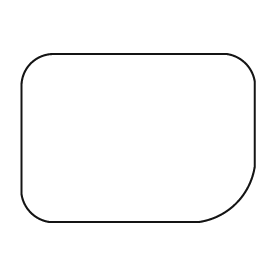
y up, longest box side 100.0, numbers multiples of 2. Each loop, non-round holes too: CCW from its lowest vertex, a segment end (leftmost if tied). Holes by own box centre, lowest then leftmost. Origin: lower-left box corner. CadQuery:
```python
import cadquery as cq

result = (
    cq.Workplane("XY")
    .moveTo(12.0, 0.0)
    .lineTo(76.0, 0.0)
    .threePointArc((92.0, 8.0), (100.0, 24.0))
    .lineTo(100.0, 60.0)
    .threePointArc((96.0, 68.0), (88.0, 72.0))
    .lineTo(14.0, 72.0)
    .threePointArc((4.0, 68.0), (0.0, 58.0))
    .lineTo(0.0, 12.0)
    .threePointArc((4.0, 4.0), (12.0, 0.0))
    .close()
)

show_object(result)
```